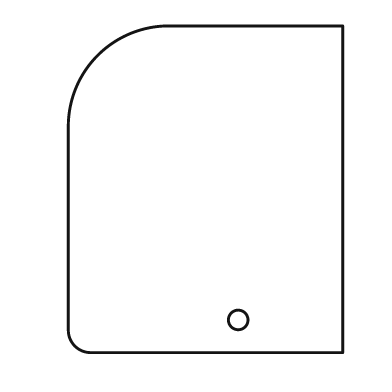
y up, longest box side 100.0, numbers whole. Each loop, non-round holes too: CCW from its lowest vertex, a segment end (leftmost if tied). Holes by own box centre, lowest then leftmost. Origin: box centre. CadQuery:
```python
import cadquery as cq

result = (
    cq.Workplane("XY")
    .moveTo(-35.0, -50.0)
    .lineTo(42.0, -50.0)
    .lineTo(42.0, 50.0)
    .lineTo(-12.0, 50.0)
    .threePointArc((-33.0, 41.0), (-42.0, 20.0))
    .lineTo(-42.0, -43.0)
    .threePointArc((-40.0, -48.0), (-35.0, -50.0))
    .close()
    .moveTo(10.0, -40.0)
    .circle(3.0)
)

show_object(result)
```